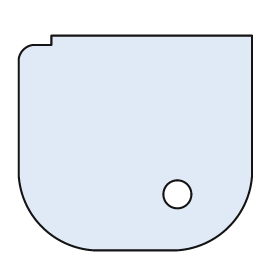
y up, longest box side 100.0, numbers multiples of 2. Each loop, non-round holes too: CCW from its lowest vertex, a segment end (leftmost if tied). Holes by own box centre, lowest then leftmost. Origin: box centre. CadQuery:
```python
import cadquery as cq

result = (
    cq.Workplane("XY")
    .moveTo(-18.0, -46.0)
    .lineTo(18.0, -46.0)
    .threePointArc((40.0, -36.0), (50.0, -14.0))
    .lineTo(50.0, 46.0)
    .lineTo(-36.0, 46.0)
    .lineTo(-36.0, 42.0)
    .lineTo(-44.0, 42.0)
    .threePointArc((-48.0, 40.0), (-50.0, 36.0))
    .lineTo(-50.0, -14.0)
    .threePointArc((-40.0, -36.0), (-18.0, -46.0))
    .close()
    .moveTo(18.0, -22.0)
    .circle(6.0)
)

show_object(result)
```